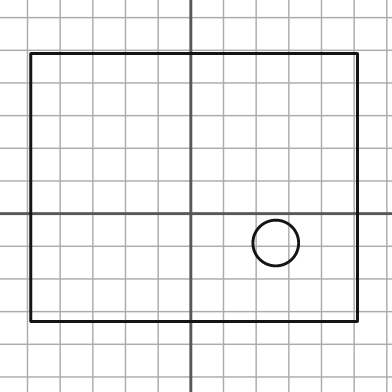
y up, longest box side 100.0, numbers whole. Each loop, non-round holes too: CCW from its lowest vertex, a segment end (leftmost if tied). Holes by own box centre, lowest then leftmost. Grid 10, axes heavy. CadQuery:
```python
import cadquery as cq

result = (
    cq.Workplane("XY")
    .moveTo(-49.0, -33.0)
    .lineTo(51.0, -33.0)
    .lineTo(51.0, 49.0)
    .lineTo(-49.0, 49.0)
    .close()
    .moveTo(26.0, -9.0)
    .circle(7.0)
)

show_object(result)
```